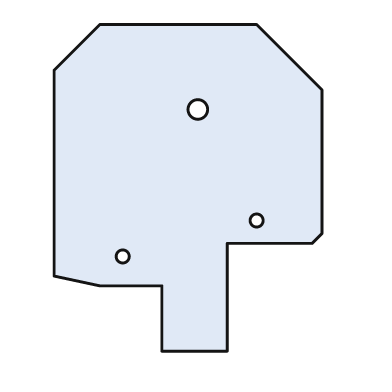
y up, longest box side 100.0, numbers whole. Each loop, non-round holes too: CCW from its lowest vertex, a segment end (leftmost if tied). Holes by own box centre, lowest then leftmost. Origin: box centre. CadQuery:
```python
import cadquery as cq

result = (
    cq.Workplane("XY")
    .moveTo(-8.0, -50.0)
    .lineTo(12.0, -50.0)
    .lineTo(12.0, -17.0)
    .lineTo(38.0, -17.0)
    .lineTo(41.0, -14.0)
    .lineTo(41.0, 30.0)
    .lineTo(21.0, 50.0)
    .lineTo(-27.0, 50.0)
    .lineTo(-41.0, 36.0)
    .lineTo(-41.0, -27.0)
    .lineTo(-27.0, -30.0)
    .lineTo(-8.0, -30.0)
    .close()
    .moveTo(-20.0, -21.0)
    .circle(2.0)
    .moveTo(21.0, -10.0)
    .circle(2.0)
    .moveTo(3.0, 24.0)
    .circle(3.0)
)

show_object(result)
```